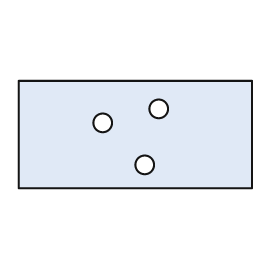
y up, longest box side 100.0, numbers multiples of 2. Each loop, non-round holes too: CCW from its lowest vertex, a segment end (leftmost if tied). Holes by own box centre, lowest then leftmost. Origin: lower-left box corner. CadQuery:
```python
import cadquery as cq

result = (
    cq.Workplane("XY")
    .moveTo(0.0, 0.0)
    .lineTo(100.0, 0.0)
    .lineTo(100.0, 46.0)
    .lineTo(0.0, 46.0)
    .close()
    .moveTo(54.0, 10.0)
    .circle(4.0)
    .moveTo(36.0, 28.0)
    .circle(4.0)
    .moveTo(60.0, 34.0)
    .circle(4.0)
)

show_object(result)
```